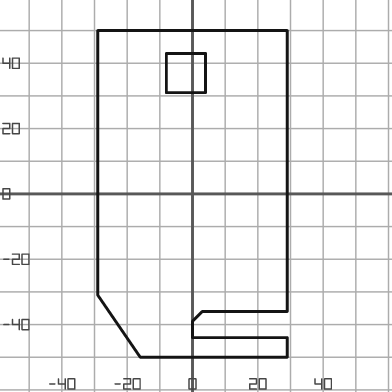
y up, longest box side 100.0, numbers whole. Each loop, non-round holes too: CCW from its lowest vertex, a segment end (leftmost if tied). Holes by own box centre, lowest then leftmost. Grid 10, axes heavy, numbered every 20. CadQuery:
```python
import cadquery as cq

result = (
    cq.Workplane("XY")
    .moveTo(-16.0, -50.0)
    .lineTo(29.0, -50.0)
    .lineTo(29.0, -44.0)
    .lineTo(0.0, -44.0)
    .lineTo(0.0, -39.0)
    .lineTo(3.0, -36.0)
    .lineTo(29.0, -36.0)
    .lineTo(29.0, 50.0)
    .lineTo(-29.0, 50.0)
    .lineTo(-29.0, -31.0)
    .close()
    .moveTo(-8.0, 31.0)
    .lineTo(4.0, 31.0)
    .lineTo(4.0, 43.0)
    .lineTo(-8.0, 43.0)
    .close()
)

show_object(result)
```